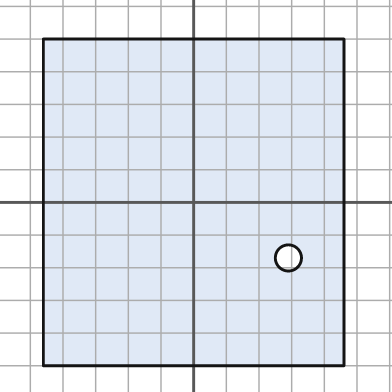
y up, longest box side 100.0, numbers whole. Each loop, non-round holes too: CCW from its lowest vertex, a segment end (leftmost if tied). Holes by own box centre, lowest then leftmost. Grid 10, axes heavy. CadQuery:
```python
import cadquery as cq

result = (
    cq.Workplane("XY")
    .moveTo(-46.0, -50.0)
    .lineTo(46.0, -50.0)
    .lineTo(46.0, 50.0)
    .lineTo(-46.0, 50.0)
    .close()
    .moveTo(29.0, -17.0)
    .circle(4.0)
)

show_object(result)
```